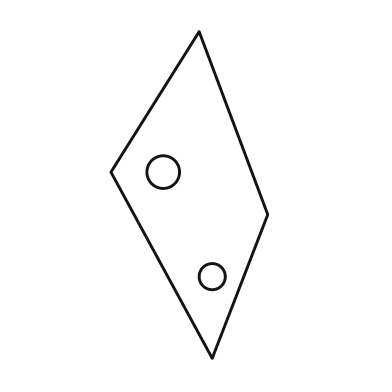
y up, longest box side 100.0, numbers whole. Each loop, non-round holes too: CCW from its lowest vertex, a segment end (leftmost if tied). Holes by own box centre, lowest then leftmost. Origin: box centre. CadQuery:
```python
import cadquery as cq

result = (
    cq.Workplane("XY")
    .moveTo(7.0, -50.0)
    .lineTo(24.0, -6.0)
    .lineTo(3.0, 50.0)
    .lineTo(-24.0, 7.0)
    .close()
    .moveTo(7.0, -25.0)
    .circle(4.0)
    .moveTo(-8.0, 7.0)
    .circle(5.0)
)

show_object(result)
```